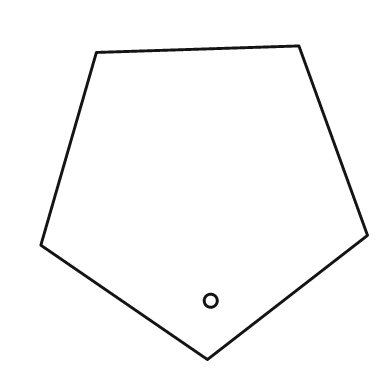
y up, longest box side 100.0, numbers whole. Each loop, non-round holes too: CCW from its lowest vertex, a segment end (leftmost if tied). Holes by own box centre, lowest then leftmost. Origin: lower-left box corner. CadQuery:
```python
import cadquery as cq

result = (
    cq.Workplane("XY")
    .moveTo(51.0, 0.0)
    .lineTo(100.0, 38.0)
    .lineTo(79.0, 96.0)
    .lineTo(17.0, 94.0)
    .lineTo(0.0, 35.0)
    .close()
    .moveTo(52.0, 18.0)
    .circle(2.0)
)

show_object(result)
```